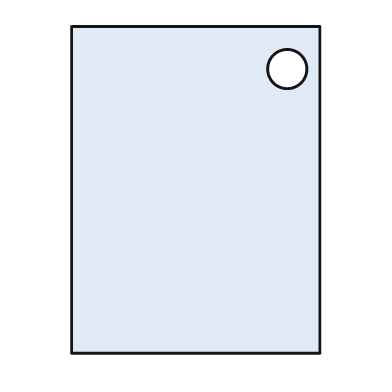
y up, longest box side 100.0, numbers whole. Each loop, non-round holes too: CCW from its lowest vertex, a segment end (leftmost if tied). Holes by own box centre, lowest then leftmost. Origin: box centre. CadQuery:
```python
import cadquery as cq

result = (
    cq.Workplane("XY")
    .moveTo(-38.0, -50.0)
    .lineTo(38.0, -50.0)
    .lineTo(38.0, 50.0)
    .lineTo(-38.0, 50.0)
    .close()
    .moveTo(28.0, 37.0)
    .circle(6.0)
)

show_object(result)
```